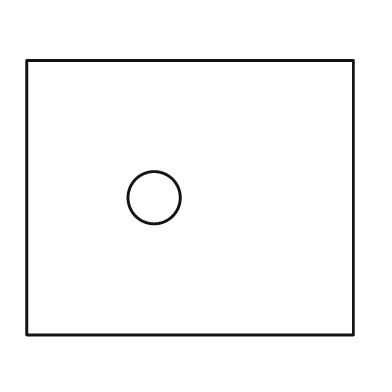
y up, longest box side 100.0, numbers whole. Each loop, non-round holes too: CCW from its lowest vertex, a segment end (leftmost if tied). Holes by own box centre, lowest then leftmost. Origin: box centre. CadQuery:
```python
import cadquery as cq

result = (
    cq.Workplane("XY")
    .moveTo(-50.0, -42.0)
    .lineTo(50.0, -42.0)
    .lineTo(50.0, 42.0)
    .lineTo(-50.0, 42.0)
    .close()
    .moveTo(-11.0, 0.0)
    .circle(8.0)
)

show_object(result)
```